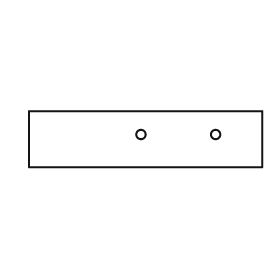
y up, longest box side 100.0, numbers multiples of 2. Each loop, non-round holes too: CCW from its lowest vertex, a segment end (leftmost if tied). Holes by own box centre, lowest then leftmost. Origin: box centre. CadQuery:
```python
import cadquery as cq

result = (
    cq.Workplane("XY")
    .moveTo(-50.0, -12.0)
    .lineTo(50.0, -12.0)
    .lineTo(50.0, 12.0)
    .lineTo(-50.0, 12.0)
    .close()
    .moveTo(-2.0, 2.0)
    .circle(2.0)
    .moveTo(30.0, 2.0)
    .circle(2.0)
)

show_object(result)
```